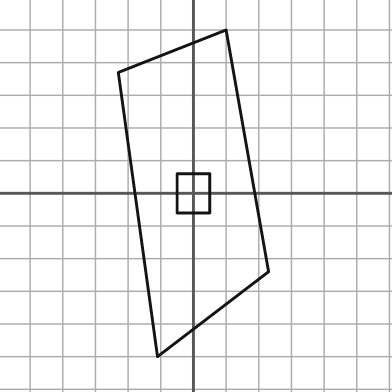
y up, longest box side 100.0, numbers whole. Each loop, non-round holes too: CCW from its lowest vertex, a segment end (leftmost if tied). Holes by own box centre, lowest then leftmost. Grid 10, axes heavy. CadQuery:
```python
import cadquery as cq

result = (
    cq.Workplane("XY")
    .moveTo(-11.0, -50.0)
    .lineTo(23.0, -24.0)
    .lineTo(10.0, 50.0)
    .lineTo(-23.0, 37.0)
    .close()
    .moveTo(-5.0, -6.0)
    .lineTo(5.0, -6.0)
    .lineTo(5.0, 6.0)
    .lineTo(-5.0, 6.0)
    .close()
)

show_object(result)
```